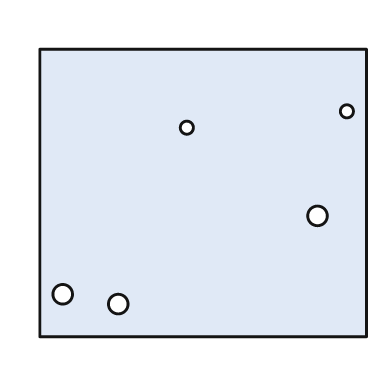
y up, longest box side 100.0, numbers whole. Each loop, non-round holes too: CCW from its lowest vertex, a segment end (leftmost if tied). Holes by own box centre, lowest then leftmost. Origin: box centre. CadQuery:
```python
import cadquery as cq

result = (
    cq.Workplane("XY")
    .moveTo(-50.0, -44.0)
    .lineTo(50.0, -44.0)
    .lineTo(50.0, 44.0)
    .lineTo(-50.0, 44.0)
    .close()
    .moveTo(-26.0, -34.0)
    .circle(3.0)
    .moveTo(-43.0, -31.0)
    .circle(3.0)
    .moveTo(35.0, -7.0)
    .circle(3.0)
    .moveTo(-5.0, 20.0)
    .circle(2.0)
    .moveTo(44.0, 25.0)
    .circle(2.0)
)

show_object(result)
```